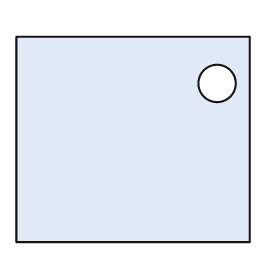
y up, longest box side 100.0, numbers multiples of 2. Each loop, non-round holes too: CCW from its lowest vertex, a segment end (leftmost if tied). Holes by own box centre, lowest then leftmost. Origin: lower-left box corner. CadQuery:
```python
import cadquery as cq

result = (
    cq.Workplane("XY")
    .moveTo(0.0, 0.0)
    .lineTo(100.0, 0.0)
    .lineTo(100.0, 88.0)
    .lineTo(0.0, 88.0)
    .close()
    .moveTo(86.0, 68.0)
    .circle(8.0)
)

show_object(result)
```